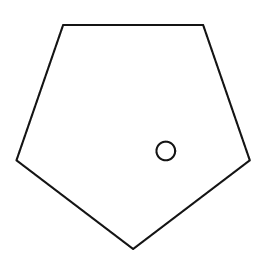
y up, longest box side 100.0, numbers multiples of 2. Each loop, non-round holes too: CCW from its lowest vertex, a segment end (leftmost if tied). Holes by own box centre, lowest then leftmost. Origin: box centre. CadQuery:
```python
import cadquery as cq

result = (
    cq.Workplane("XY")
    .moveTo(0.0, -48.0)
    .lineTo(50.0, -10.0)
    .lineTo(30.0, 48.0)
    .lineTo(-30.0, 48.0)
    .lineTo(-50.0, -10.0)
    .close()
    .moveTo(14.0, -6.0)
    .circle(4.0)
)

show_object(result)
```